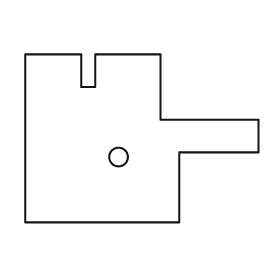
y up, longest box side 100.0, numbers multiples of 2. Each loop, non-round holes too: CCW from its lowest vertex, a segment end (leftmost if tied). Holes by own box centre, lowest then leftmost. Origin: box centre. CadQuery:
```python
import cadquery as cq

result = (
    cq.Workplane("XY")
    .moveTo(-50.0, -36.0)
    .lineTo(16.0, -36.0)
    .lineTo(16.0, -6.0)
    .lineTo(50.0, -6.0)
    .lineTo(50.0, 8.0)
    .lineTo(8.0, 8.0)
    .lineTo(8.0, 36.0)
    .lineTo(-20.0, 36.0)
    .lineTo(-20.0, 22.0)
    .lineTo(-26.0, 22.0)
    .lineTo(-26.0, 36.0)
    .lineTo(-50.0, 36.0)
    .close()
    .moveTo(-10.0, -8.0)
    .circle(4.0)
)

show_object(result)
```